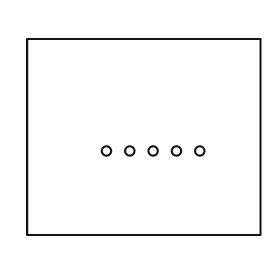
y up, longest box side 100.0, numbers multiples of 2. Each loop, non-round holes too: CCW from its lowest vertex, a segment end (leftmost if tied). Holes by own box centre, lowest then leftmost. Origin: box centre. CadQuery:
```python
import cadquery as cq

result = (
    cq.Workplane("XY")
    .moveTo(-50.0, -42.0)
    .lineTo(50.0, -42.0)
    .lineTo(50.0, 42.0)
    .lineTo(-50.0, 42.0)
    .close()
    .moveTo(-16.0, -6.0)
    .circle(2.0)
    .moveTo(-6.0, -6.0)
    .circle(2.0)
    .moveTo(4.0, -6.0)
    .circle(2.0)
    .moveTo(14.0, -6.0)
    .circle(2.0)
    .moveTo(24.0, -6.0)
    .circle(2.0)
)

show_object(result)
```